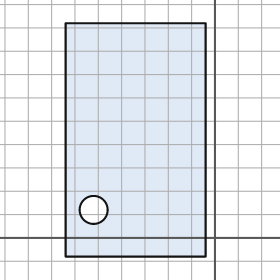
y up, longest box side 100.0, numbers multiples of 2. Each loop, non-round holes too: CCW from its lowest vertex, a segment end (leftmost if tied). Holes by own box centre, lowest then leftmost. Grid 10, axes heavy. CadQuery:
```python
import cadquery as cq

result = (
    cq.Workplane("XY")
    .moveTo(-64.0, -8.0)
    .lineTo(-4.0, -8.0)
    .lineTo(-4.0, 92.0)
    .lineTo(-64.0, 92.0)
    .close()
    .moveTo(-52.0, 12.0)
    .circle(6.0)
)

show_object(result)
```